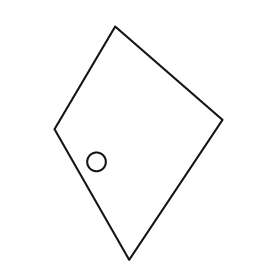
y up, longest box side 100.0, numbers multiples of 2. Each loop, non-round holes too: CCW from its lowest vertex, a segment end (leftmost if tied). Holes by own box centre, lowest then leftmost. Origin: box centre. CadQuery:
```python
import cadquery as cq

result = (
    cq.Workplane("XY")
    .moveTo(-4.0, -50.0)
    .lineTo(36.0, 10.0)
    .lineTo(-10.0, 50.0)
    .lineTo(-36.0, 6.0)
    .close()
    .moveTo(-18.0, -8.0)
    .circle(4.0)
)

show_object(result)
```